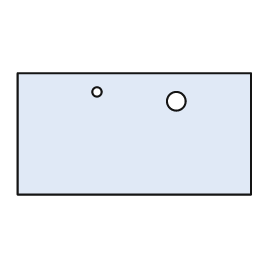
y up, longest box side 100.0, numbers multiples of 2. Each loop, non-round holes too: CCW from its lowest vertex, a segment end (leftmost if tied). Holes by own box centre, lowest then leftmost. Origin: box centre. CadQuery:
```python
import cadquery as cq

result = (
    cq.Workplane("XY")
    .moveTo(-50.0, -26.0)
    .lineTo(50.0, -26.0)
    .lineTo(50.0, 26.0)
    .lineTo(-50.0, 26.0)
    .close()
    .moveTo(18.0, 14.0)
    .circle(4.0)
    .moveTo(-16.0, 18.0)
    .circle(2.0)
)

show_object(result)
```